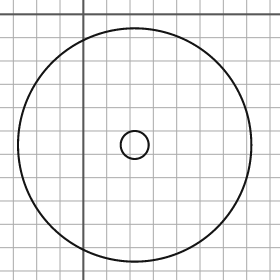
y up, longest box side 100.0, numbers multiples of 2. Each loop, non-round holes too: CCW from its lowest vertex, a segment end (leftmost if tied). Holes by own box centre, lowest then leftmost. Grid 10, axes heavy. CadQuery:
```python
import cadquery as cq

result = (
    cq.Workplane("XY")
    .moveTo(22.0, -56.0)
    .circle(50.0)
    .moveTo(22.0, -56.0)
    .circle(6.0)
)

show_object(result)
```